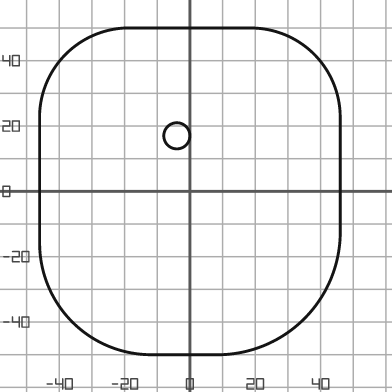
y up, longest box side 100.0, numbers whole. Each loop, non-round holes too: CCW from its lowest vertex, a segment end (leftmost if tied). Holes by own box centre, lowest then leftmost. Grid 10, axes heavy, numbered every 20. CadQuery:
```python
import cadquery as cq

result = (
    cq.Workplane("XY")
    .moveTo(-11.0, -50.0)
    .lineTo(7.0, -50.0)
    .threePointArc((35.0, -39.0), (46.0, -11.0))
    .lineTo(46.0, 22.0)
    .threePointArc((38.0, 42.0), (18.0, 50.0))
    .lineTo(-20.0, 50.0)
    .threePointArc((-38.0, 42.0), (-46.0, 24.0))
    .lineTo(-46.0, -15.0)
    .threePointArc((-36.0, -40.0), (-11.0, -50.0))
    .close()
    .moveTo(-4.0, 17.0)
    .circle(4.0)
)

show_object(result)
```